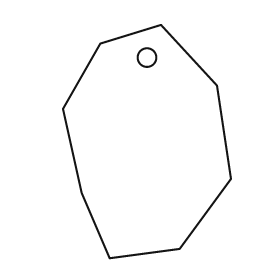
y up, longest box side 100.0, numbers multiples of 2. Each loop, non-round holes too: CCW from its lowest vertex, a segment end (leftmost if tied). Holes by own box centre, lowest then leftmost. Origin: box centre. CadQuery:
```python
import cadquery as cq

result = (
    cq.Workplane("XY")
    .moveTo(-16.0, -50.0)
    .lineTo(14.0, -46.0)
    .lineTo(36.0, -16.0)
    .lineTo(30.0, 24.0)
    .lineTo(6.0, 50.0)
    .lineTo(-20.0, 42.0)
    .lineTo(-36.0, 14.0)
    .lineTo(-28.0, -22.0)
    .close()
    .moveTo(0.0, 36.0)
    .circle(4.0)
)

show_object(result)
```